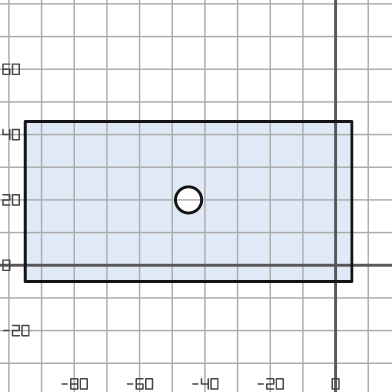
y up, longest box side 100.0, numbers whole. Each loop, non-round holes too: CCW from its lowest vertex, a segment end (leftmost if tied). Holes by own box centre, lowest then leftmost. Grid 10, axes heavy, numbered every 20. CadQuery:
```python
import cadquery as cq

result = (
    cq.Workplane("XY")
    .moveTo(-95.0, -5.0)
    .lineTo(5.0, -5.0)
    .lineTo(5.0, 44.0)
    .lineTo(-95.0, 44.0)
    .close()
    .moveTo(-45.0, 20.0)
    .circle(4.0)
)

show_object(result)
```